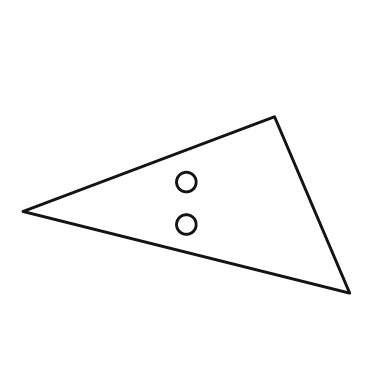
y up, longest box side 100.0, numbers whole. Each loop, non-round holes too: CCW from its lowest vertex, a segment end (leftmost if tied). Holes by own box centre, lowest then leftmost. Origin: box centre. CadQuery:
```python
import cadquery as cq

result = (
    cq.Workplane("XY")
    .moveTo(50.0, -27.0)
    .lineTo(27.0, 27.0)
    .lineTo(-50.0, -2.0)
    .close()
    .moveTo(0.0, -6.0)
    .circle(3.0)
    .moveTo(0.0, 7.0)
    .circle(3.0)
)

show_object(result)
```